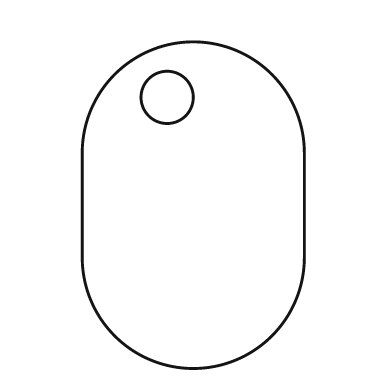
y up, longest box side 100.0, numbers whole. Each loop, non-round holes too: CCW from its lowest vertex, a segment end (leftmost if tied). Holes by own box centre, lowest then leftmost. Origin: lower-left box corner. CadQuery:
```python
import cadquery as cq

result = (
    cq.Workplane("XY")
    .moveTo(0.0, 34.0)
    .threePointArc((34.0, 0.0), (68.0, 34.0))
    .lineTo(68.0, 66.0)
    .threePointArc((34.0, 100.0), (0.0, 66.0))
    .close()
    .moveTo(26.0, 83.0)
    .circle(8.0)
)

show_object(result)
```